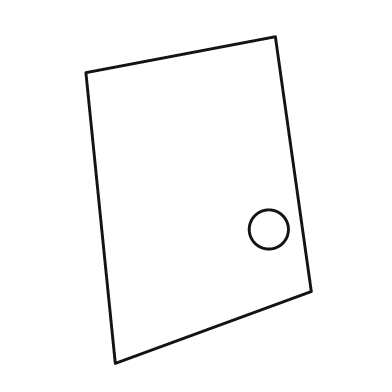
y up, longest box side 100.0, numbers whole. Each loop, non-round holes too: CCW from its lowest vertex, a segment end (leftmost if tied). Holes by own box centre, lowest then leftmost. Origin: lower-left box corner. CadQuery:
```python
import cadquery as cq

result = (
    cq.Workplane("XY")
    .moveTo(9.0, 0.0)
    .lineTo(69.0, 22.0)
    .lineTo(58.0, 100.0)
    .lineTo(0.0, 89.0)
    .close()
    .moveTo(56.0, 41.0)
    .circle(6.0)
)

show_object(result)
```